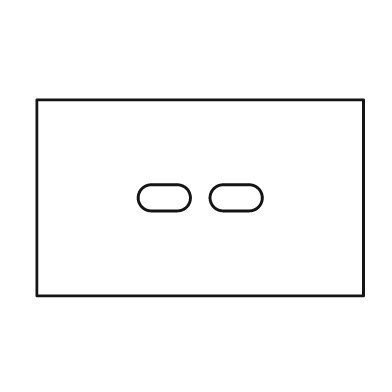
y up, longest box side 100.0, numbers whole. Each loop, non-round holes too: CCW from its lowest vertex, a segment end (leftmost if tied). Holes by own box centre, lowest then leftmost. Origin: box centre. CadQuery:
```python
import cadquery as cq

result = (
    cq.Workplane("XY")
    .moveTo(-50.0, -30.0)
    .lineTo(50.0, -30.0)
    .lineTo(50.0, 30.0)
    .lineTo(-50.0, 30.0)
    .close()
    .moveTo(-15.0, -4.0)
    .lineTo(-7.0, -4.0)
    .threePointArc((-3.0, 0.0), (-7.0, 4.0))
    .lineTo(-15.0, 4.0)
    .threePointArc((-19.0, 0.0), (-15.0, -4.0))
    .close()
    .moveTo(7.0, -4.0)
    .lineTo(15.0, -4.0)
    .threePointArc((19.0, 0.0), (15.0, 4.0))
    .lineTo(7.0, 4.0)
    .threePointArc((3.0, 0.0), (7.0, -4.0))
    .close()
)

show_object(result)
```